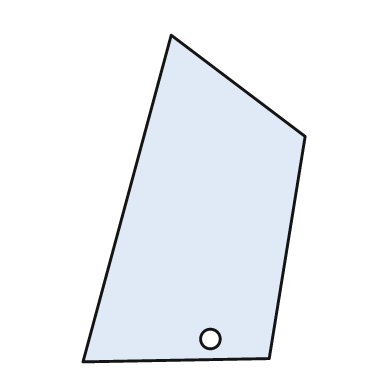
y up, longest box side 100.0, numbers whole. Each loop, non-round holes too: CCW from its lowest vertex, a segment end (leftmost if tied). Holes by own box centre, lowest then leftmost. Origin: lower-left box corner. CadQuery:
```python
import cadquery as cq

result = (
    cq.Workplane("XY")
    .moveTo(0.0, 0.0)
    .lineTo(57.0, 1.0)
    .lineTo(68.0, 69.0)
    .lineTo(27.0, 100.0)
    .close()
    .moveTo(39.0, 7.0)
    .circle(3.0)
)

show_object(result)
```